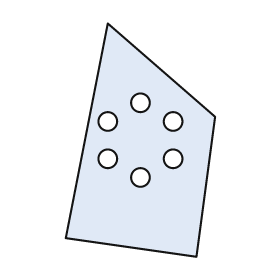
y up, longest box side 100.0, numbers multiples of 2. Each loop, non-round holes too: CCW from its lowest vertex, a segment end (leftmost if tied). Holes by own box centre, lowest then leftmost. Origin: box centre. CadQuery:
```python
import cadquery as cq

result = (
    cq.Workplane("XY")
    .moveTo(24.0, -50.0)
    .lineTo(32.0, 10.0)
    .lineTo(-14.0, 50.0)
    .lineTo(-32.0, -42.0)
    .close()
    .moveTo(0.0, -16.0)
    .circle(4.0)
    .moveTo(-14.0, -8.0)
    .circle(4.0)
    .moveTo(14.0, -8.0)
    .circle(4.0)
    .moveTo(-14.0, 8.0)
    .circle(4.0)
    .moveTo(14.0, 8.0)
    .circle(4.0)
    .moveTo(0.0, 16.0)
    .circle(4.0)
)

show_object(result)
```